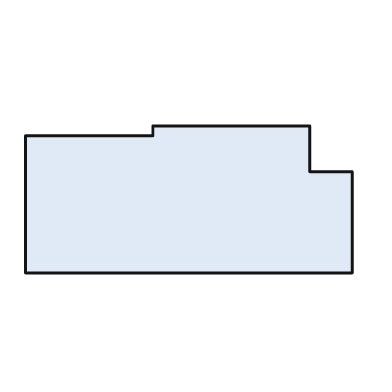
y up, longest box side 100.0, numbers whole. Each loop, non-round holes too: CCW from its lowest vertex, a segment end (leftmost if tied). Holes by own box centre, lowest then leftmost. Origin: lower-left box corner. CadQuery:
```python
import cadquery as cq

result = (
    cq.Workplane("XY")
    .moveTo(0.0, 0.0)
    .lineTo(100.0, 0.0)
    .lineTo(100.0, 31.0)
    .lineTo(87.0, 31.0)
    .lineTo(87.0, 45.0)
    .lineTo(39.0, 45.0)
    .lineTo(39.0, 42.0)
    .lineTo(0.0, 42.0)
    .close()
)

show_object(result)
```